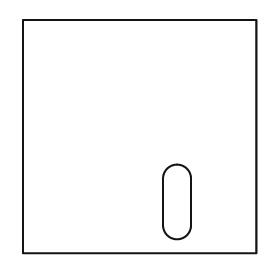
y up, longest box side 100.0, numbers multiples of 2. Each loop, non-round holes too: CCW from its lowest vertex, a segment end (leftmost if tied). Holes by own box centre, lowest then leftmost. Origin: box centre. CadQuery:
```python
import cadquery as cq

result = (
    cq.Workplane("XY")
    .moveTo(-50.0, -50.0)
    .lineTo(50.0, -50.0)
    .lineTo(50.0, 50.0)
    .lineTo(-50.0, 50.0)
    .close()
    .moveTo(10.0, -38.0)
    .threePointArc((16.0, -44.0), (22.0, -38.0))
    .lineTo(22.0, -18.0)
    .threePointArc((16.0, -12.0), (10.0, -18.0))
    .close()
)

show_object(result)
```